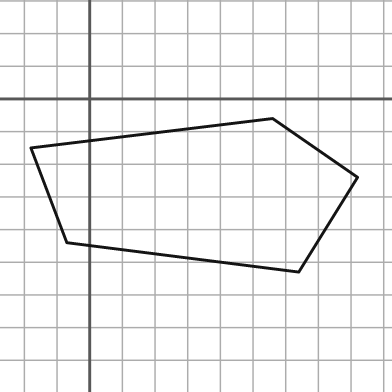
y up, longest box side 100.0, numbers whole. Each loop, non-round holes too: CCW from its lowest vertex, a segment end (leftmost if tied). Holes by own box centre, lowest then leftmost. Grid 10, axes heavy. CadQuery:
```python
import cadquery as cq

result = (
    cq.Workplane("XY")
    .moveTo(64.0, -53.0)
    .lineTo(82.0, -24.0)
    .lineTo(56.0, -6.0)
    .lineTo(-18.0, -15.0)
    .lineTo(-7.0, -44.0)
    .close()
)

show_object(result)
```